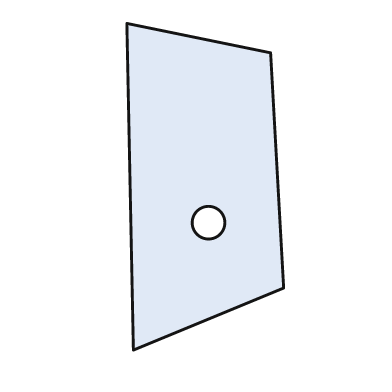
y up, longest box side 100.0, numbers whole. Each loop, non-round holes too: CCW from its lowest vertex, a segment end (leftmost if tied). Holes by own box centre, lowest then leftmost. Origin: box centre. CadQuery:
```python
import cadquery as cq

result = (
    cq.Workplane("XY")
    .moveTo(-22.0, -50.0)
    .lineTo(24.0, -31.0)
    .lineTo(20.0, 41.0)
    .lineTo(-24.0, 50.0)
    .close()
    .moveTo(1.0, -11.0)
    .circle(5.0)
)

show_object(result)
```